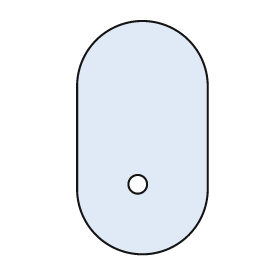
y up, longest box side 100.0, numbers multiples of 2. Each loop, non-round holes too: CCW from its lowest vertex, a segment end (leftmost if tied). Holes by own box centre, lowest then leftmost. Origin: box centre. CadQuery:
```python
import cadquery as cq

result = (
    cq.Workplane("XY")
    .moveTo(-28.0, -22.0)
    .threePointArc((0.0, -50.0), (28.0, -22.0))
    .lineTo(28.0, 22.0)
    .threePointArc((0.0, 50.0), (-28.0, 22.0))
    .close()
    .moveTo(-2.0, -20.0)
    .circle(4.0)
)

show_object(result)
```